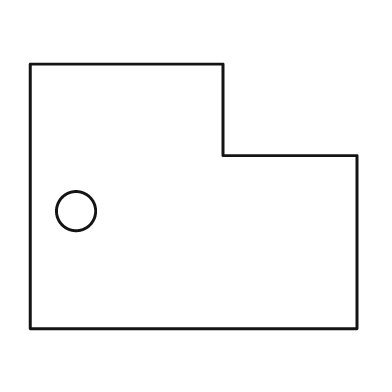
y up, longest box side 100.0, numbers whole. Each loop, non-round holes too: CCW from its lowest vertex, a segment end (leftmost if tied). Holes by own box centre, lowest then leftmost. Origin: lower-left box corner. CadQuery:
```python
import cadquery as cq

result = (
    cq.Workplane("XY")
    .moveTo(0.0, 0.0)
    .lineTo(100.0, 0.0)
    .lineTo(100.0, 53.0)
    .lineTo(59.0, 53.0)
    .lineTo(59.0, 81.0)
    .lineTo(0.0, 81.0)
    .close()
    .moveTo(14.0, 36.0)
    .circle(6.0)
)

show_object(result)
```